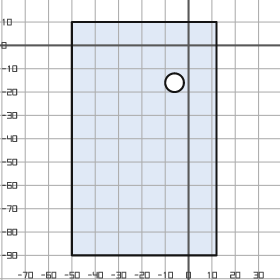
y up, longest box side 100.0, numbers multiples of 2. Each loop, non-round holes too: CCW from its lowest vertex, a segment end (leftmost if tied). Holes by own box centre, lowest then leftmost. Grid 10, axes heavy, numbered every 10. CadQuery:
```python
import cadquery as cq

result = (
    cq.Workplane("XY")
    .moveTo(-50.0, -90.0)
    .lineTo(12.0, -90.0)
    .lineTo(12.0, 10.0)
    .lineTo(-50.0, 10.0)
    .close()
    .moveTo(-6.0, -16.0)
    .circle(4.0)
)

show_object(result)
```